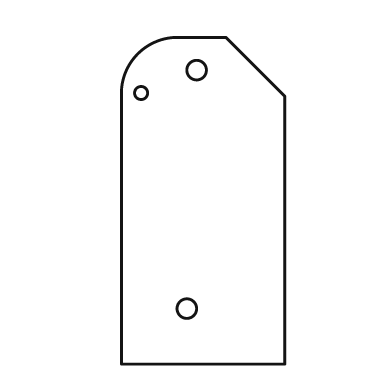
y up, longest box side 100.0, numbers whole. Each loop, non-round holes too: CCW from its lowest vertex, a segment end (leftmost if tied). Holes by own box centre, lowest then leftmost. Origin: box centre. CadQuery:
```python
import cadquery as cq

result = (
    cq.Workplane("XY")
    .moveTo(-25.0, -50.0)
    .lineTo(25.0, -50.0)
    .lineTo(25.0, 32.0)
    .lineTo(7.0, 50.0)
    .lineTo(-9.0, 50.0)
    .threePointArc((-20.0, 45.0), (-25.0, 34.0))
    .close()
    .moveTo(-5.0, -33.0)
    .circle(3.0)
    .moveTo(-19.0, 33.0)
    .circle(2.0)
    .moveTo(-2.0, 40.0)
    .circle(3.0)
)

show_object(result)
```